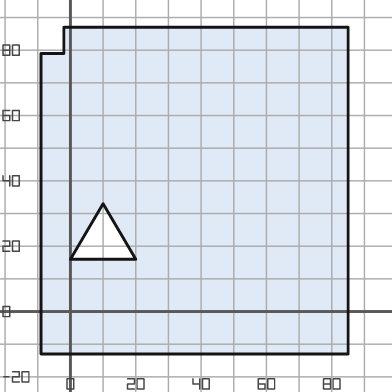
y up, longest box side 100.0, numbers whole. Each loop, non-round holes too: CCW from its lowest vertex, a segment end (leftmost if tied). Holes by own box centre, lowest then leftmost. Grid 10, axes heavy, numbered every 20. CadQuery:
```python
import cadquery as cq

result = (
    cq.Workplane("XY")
    .moveTo(-9.0, -13.0)
    .lineTo(85.0, -13.0)
    .lineTo(85.0, 87.0)
    .lineTo(-2.0, 87.0)
    .lineTo(-2.0, 79.0)
    .lineTo(-9.0, 79.0)
    .close()
    .moveTo(0.0, 16.0)
    .lineTo(20.0, 16.0)
    .lineTo(10.0, 33.0)
    .close()
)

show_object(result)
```